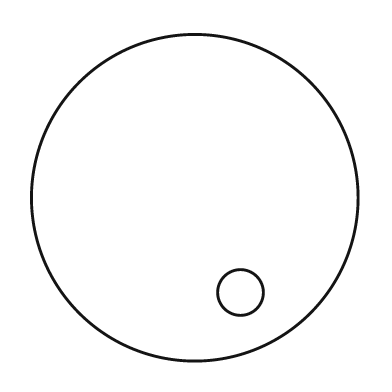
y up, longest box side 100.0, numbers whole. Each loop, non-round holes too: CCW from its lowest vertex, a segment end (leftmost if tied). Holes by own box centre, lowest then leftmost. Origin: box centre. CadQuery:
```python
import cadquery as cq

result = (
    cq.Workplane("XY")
    .moveTo(0.0, 0.0)
    .circle(50.0)
    .moveTo(14.0, -29.0)
    .circle(7.0)
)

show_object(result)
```